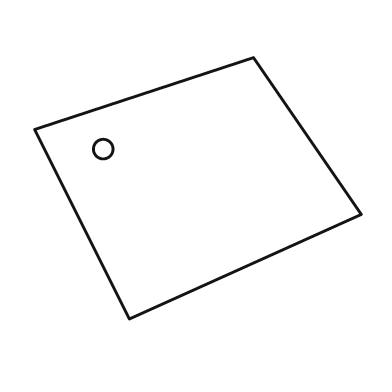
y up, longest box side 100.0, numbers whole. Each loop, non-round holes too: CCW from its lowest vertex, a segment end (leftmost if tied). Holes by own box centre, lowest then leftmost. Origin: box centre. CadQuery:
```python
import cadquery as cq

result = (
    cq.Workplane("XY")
    .moveTo(-21.0, -40.0)
    .lineTo(50.0, -8.0)
    .lineTo(17.0, 40.0)
    .lineTo(-50.0, 18.0)
    .close()
    .moveTo(-29.0, 12.0)
    .circle(3.0)
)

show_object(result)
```